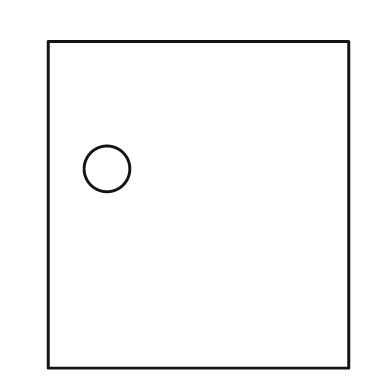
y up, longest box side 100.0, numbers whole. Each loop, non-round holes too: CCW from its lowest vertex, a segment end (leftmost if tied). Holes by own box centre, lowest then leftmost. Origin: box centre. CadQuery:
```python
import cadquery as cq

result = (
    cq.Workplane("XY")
    .moveTo(-46.0, -50.0)
    .lineTo(46.0, -50.0)
    .lineTo(46.0, 50.0)
    .lineTo(-46.0, 50.0)
    .close()
    .moveTo(-28.0, 11.0)
    .circle(7.0)
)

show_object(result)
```